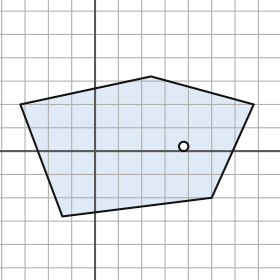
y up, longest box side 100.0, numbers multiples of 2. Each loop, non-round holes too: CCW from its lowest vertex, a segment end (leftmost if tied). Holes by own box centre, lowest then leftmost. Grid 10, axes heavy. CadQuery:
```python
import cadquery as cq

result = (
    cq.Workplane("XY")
    .moveTo(-14.0, -28.0)
    .lineTo(50.0, -20.0)
    .lineTo(68.0, 20.0)
    .lineTo(24.0, 32.0)
    .lineTo(-32.0, 20.0)
    .close()
    .moveTo(38.0, 2.0)
    .circle(2.0)
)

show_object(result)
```